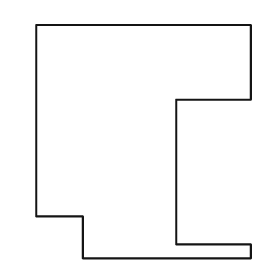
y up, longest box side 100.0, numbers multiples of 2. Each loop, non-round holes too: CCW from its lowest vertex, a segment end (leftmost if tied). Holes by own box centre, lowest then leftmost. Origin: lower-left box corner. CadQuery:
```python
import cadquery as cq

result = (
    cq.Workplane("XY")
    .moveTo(20.0, 0.0)
    .lineTo(92.0, 0.0)
    .lineTo(92.0, 6.0)
    .lineTo(60.0, 6.0)
    .lineTo(60.0, 68.0)
    .lineTo(92.0, 68.0)
    .lineTo(92.0, 100.0)
    .lineTo(0.0, 100.0)
    .lineTo(0.0, 18.0)
    .lineTo(20.0, 18.0)
    .close()
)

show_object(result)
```